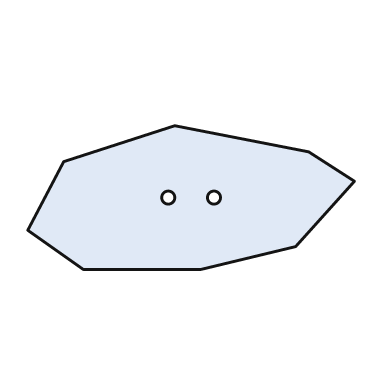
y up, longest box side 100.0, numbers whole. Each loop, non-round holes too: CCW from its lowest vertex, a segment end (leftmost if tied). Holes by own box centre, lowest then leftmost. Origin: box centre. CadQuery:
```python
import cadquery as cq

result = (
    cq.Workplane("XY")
    .moveTo(-33.0, -22.0)
    .lineTo(3.0, -22.0)
    .lineTo(32.0, -15.0)
    .lineTo(50.0, 5.0)
    .lineTo(36.0, 14.0)
    .lineTo(-5.0, 22.0)
    .lineTo(-39.0, 11.0)
    .lineTo(-50.0, -10.0)
    .close()
    .moveTo(-7.0, 0.0)
    .circle(2.0)
    .moveTo(7.0, 0.0)
    .circle(2.0)
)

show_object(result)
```